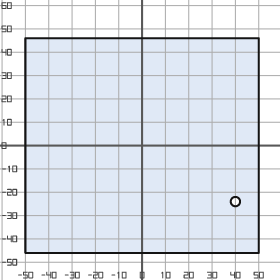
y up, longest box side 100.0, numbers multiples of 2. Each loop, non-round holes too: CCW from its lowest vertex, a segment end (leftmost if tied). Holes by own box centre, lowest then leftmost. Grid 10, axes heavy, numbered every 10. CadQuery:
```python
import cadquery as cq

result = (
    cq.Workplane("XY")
    .moveTo(-50.0, -46.0)
    .lineTo(50.0, -46.0)
    .lineTo(50.0, 46.0)
    .lineTo(-50.0, 46.0)
    .close()
    .moveTo(40.0, -24.0)
    .circle(2.0)
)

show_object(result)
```